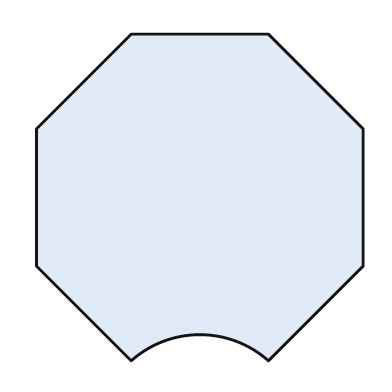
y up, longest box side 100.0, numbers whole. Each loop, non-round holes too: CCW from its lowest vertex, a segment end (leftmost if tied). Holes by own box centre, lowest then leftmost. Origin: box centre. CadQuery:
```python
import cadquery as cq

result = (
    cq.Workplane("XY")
    .moveTo(-21.0, -50.0)
    .threePointArc((0.0, -42.0), (21.0, -50.0))
    .lineTo(50.0, -21.0)
    .lineTo(50.0, 21.0)
    .lineTo(21.0, 50.0)
    .lineTo(-21.0, 50.0)
    .lineTo(-50.0, 21.0)
    .lineTo(-50.0, -21.0)
    .close()
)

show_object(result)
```